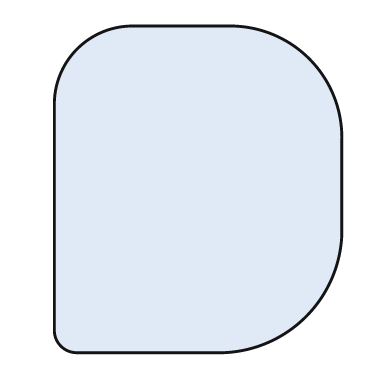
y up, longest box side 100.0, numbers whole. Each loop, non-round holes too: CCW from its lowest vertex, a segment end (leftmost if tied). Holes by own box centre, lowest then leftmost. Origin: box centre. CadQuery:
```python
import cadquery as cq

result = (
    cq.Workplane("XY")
    .moveTo(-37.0, -50.0)
    .lineTo(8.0, -50.0)
    .threePointArc((33.0, -39.0), (44.0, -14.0))
    .lineTo(44.0, 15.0)
    .threePointArc((34.0, 40.0), (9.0, 50.0))
    .lineTo(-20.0, 50.0)
    .threePointArc((-37.0, 43.0), (-44.0, 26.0))
    .lineTo(-44.0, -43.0)
    .threePointArc((-42.0, -48.0), (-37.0, -50.0))
    .close()
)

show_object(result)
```